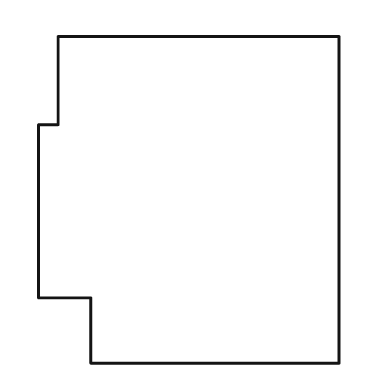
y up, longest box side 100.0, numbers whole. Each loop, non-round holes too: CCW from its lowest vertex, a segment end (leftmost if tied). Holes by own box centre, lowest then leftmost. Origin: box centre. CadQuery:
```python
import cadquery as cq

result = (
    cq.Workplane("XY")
    .moveTo(-30.0, -50.0)
    .lineTo(46.0, -50.0)
    .lineTo(46.0, 50.0)
    .lineTo(-40.0, 50.0)
    .lineTo(-40.0, 23.0)
    .lineTo(-46.0, 23.0)
    .lineTo(-46.0, -30.0)
    .lineTo(-30.0, -30.0)
    .close()
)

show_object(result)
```